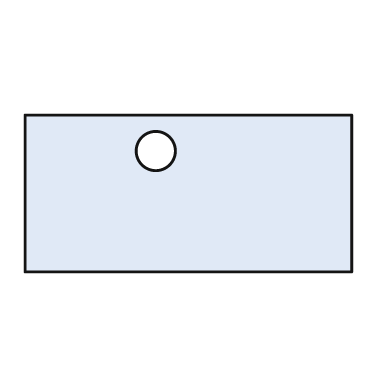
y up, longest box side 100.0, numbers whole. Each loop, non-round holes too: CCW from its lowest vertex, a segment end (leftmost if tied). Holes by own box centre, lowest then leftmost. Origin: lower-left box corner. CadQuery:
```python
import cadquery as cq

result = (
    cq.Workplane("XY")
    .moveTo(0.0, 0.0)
    .lineTo(100.0, 0.0)
    .lineTo(100.0, 48.0)
    .lineTo(0.0, 48.0)
    .close()
    .moveTo(40.0, 37.0)
    .circle(6.0)
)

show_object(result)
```